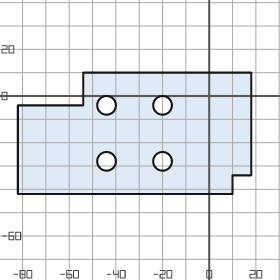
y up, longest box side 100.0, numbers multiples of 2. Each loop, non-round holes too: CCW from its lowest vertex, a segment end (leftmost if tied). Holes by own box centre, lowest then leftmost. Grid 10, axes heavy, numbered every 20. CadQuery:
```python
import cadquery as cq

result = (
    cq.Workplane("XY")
    .moveTo(-82.0, -42.0)
    .lineTo(10.0, -42.0)
    .lineTo(10.0, -34.0)
    .lineTo(18.0, -34.0)
    .lineTo(18.0, 10.0)
    .lineTo(-54.0, 10.0)
    .lineTo(-54.0, -4.0)
    .lineTo(-82.0, -4.0)
    .close()
    .moveTo(-44.0, -28.0)
    .circle(4.0)
    .moveTo(-20.0, -28.0)
    .circle(4.0)
    .moveTo(-44.0, -4.0)
    .circle(4.0)
    .moveTo(-20.0, -4.0)
    .circle(4.0)
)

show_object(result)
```